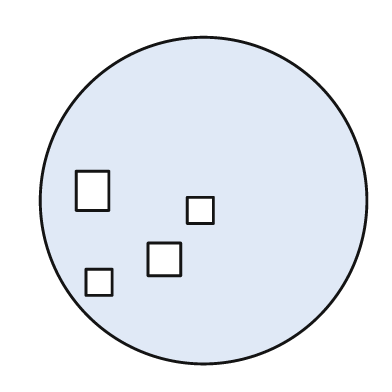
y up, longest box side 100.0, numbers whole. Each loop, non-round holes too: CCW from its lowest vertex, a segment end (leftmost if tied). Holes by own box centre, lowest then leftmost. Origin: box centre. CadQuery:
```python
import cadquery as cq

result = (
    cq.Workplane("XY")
    .moveTo(0.0, 0.0)
    .circle(50.0)
    .moveTo(-36.0, -29.0)
    .lineTo(-28.0, -29.0)
    .lineTo(-28.0, -21.0)
    .lineTo(-36.0, -21.0)
    .close()
    .moveTo(-17.0, -23.0)
    .lineTo(-7.0, -23.0)
    .lineTo(-7.0, -13.0)
    .lineTo(-17.0, -13.0)
    .close()
    .moveTo(-5.0, -7.0)
    .lineTo(3.0, -7.0)
    .lineTo(3.0, 1.0)
    .lineTo(-5.0, 1.0)
    .close()
    .moveTo(-39.0, -3.0)
    .lineTo(-29.0, -3.0)
    .lineTo(-29.0, 9.0)
    .lineTo(-39.0, 9.0)
    .close()
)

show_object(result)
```